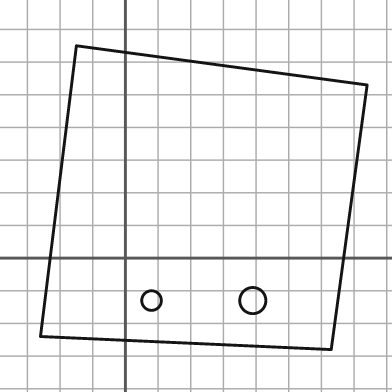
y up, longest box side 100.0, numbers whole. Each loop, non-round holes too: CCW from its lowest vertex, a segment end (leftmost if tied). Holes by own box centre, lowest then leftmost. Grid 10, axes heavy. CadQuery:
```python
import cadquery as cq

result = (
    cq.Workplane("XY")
    .moveTo(63.0, -28.0)
    .lineTo(74.0, 53.0)
    .lineTo(-15.0, 65.0)
    .lineTo(-26.0, -24.0)
    .close()
    .moveTo(8.0, -13.0)
    .circle(3.0)
    .moveTo(39.0, -13.0)
    .circle(4.0)
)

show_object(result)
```